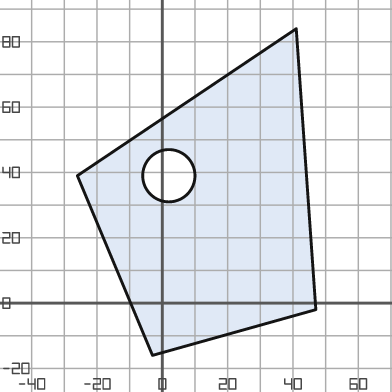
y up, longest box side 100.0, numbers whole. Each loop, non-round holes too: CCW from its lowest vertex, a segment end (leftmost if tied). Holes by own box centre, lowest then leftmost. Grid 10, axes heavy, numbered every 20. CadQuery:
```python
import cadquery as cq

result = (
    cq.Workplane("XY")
    .moveTo(-3.0, -16.0)
    .lineTo(47.0, -2.0)
    .lineTo(41.0, 84.0)
    .lineTo(-26.0, 39.0)
    .close()
    .moveTo(2.0, 39.0)
    .circle(8.0)
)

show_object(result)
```